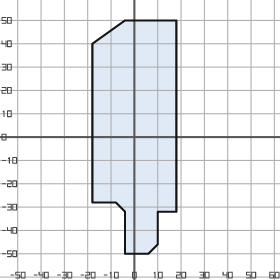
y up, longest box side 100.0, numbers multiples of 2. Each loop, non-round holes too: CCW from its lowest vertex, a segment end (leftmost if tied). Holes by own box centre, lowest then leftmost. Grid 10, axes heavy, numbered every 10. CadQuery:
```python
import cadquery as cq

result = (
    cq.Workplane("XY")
    .moveTo(-4.0, -50.0)
    .lineTo(6.0, -50.0)
    .lineTo(10.0, -46.0)
    .lineTo(10.0, -32.0)
    .lineTo(18.0, -32.0)
    .lineTo(18.0, 50.0)
    .lineTo(-4.0, 50.0)
    .lineTo(-18.0, 40.0)
    .lineTo(-18.0, -28.0)
    .lineTo(-8.0, -28.0)
    .lineTo(-4.0, -32.0)
    .close()
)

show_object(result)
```